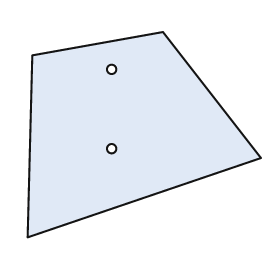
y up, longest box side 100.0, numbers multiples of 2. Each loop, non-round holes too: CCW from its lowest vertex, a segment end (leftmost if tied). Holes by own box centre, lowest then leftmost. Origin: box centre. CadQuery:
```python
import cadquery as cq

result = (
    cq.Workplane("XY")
    .moveTo(-50.0, -44.0)
    .lineTo(50.0, -10.0)
    .lineTo(8.0, 44.0)
    .lineTo(-48.0, 34.0)
    .close()
    .moveTo(-14.0, -6.0)
    .circle(2.0)
    .moveTo(-14.0, 28.0)
    .circle(2.0)
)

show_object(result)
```